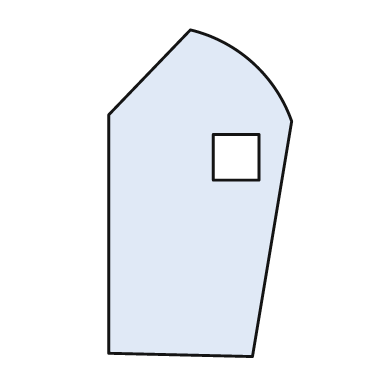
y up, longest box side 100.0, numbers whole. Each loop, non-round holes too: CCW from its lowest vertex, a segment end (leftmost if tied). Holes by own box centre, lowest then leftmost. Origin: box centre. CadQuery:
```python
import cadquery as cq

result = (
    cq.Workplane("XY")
    .moveTo(16.0, -50.0)
    .lineTo(28.0, 22.0)
    .threePointArc((16.0, 40.0), (-3.0, 50.0))
    .lineTo(-28.0, 24.0)
    .lineTo(-28.0, -49.0)
    .close()
    .moveTo(4.0, 4.0)
    .lineTo(18.0, 4.0)
    .lineTo(18.0, 18.0)
    .lineTo(4.0, 18.0)
    .close()
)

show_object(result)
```